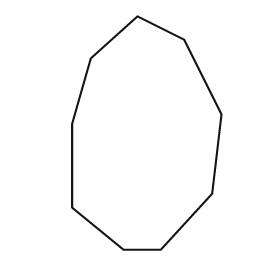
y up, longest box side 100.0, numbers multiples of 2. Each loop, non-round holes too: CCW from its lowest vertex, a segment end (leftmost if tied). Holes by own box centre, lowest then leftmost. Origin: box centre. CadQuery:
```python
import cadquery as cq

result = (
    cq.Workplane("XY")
    .moveTo(-10.0, -50.0)
    .lineTo(6.0, -50.0)
    .lineTo(28.0, -26.0)
    .lineTo(32.0, 8.0)
    .lineTo(16.0, 40.0)
    .lineTo(-4.0, 50.0)
    .lineTo(-24.0, 32.0)
    .lineTo(-32.0, 4.0)
    .lineTo(-32.0, -32.0)
    .close()
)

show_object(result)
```